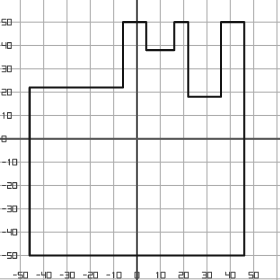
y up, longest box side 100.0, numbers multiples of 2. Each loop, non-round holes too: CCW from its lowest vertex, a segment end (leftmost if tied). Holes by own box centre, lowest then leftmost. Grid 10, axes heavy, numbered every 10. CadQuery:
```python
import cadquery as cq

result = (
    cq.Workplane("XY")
    .moveTo(-46.0, -50.0)
    .lineTo(46.0, -50.0)
    .lineTo(46.0, 50.0)
    .lineTo(36.0, 50.0)
    .lineTo(36.0, 18.0)
    .lineTo(22.0, 18.0)
    .lineTo(22.0, 50.0)
    .lineTo(16.0, 50.0)
    .lineTo(16.0, 38.0)
    .lineTo(4.0, 38.0)
    .lineTo(4.0, 50.0)
    .lineTo(-6.0, 50.0)
    .lineTo(-6.0, 22.0)
    .lineTo(-46.0, 22.0)
    .close()
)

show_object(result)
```